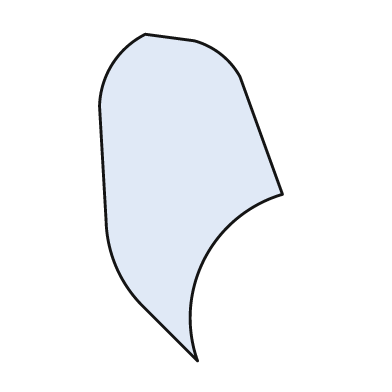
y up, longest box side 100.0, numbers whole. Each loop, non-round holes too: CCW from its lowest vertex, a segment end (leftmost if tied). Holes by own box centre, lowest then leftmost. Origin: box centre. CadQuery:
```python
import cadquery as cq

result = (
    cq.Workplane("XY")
    .moveTo(2.0, -50.0)
    .threePointArc((4.0, -19.0), (28.0, 1.0))
    .lineTo(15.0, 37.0)
    .threePointArc((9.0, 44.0), (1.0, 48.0))
    .lineTo(-14.0, 50.0)
    .threePointArc((-24.0, 41.0), (-28.0, 28.0))
    .lineTo(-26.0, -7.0)
    .threePointArc((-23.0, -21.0), (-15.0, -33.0))
    .close()
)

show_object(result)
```